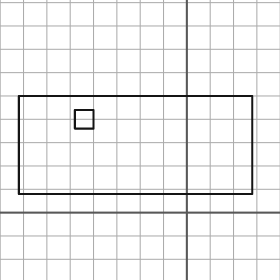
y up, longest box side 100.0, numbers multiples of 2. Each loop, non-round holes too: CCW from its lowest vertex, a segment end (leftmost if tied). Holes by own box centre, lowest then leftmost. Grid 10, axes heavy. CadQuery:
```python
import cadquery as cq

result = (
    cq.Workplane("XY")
    .moveTo(-72.0, 8.0)
    .lineTo(28.0, 8.0)
    .lineTo(28.0, 50.0)
    .lineTo(-72.0, 50.0)
    .close()
    .moveTo(-48.0, 36.0)
    .lineTo(-40.0, 36.0)
    .lineTo(-40.0, 44.0)
    .lineTo(-48.0, 44.0)
    .close()
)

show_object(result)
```